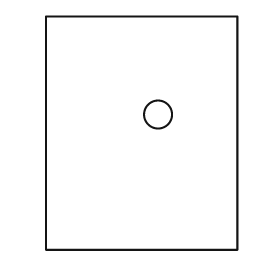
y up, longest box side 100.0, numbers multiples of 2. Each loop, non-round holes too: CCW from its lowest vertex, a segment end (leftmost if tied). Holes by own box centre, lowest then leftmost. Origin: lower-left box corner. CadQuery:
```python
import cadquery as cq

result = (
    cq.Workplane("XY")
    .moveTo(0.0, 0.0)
    .lineTo(82.0, 0.0)
    .lineTo(82.0, 100.0)
    .lineTo(0.0, 100.0)
    .close()
    .moveTo(48.0, 58.0)
    .circle(6.0)
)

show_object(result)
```